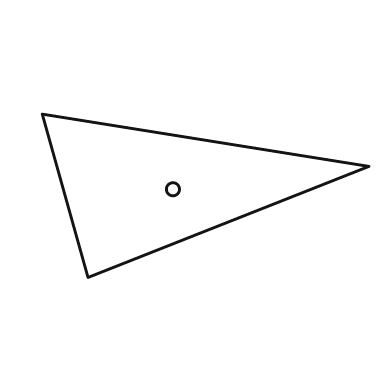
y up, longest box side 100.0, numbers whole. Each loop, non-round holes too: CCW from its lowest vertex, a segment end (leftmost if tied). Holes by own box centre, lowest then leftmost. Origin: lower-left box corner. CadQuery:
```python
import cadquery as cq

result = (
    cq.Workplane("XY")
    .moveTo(14.0, 0.0)
    .lineTo(100.0, 34.0)
    .lineTo(0.0, 50.0)
    .close()
    .moveTo(40.0, 27.0)
    .circle(2.0)
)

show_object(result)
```